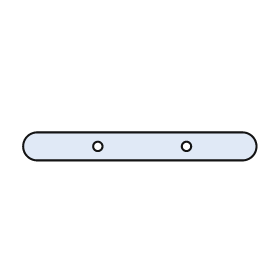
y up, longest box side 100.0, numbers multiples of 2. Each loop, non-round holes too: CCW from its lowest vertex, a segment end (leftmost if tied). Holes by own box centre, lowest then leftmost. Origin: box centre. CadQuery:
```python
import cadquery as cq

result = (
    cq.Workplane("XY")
    .moveTo(-44.0, -6.0)
    .lineTo(44.0, -6.0)
    .threePointArc((50.0, 0.0), (44.0, 6.0))
    .lineTo(-44.0, 6.0)
    .threePointArc((-50.0, 0.0), (-44.0, -6.0))
    .close()
    .moveTo(-18.0, 0.0)
    .circle(2.0)
    .moveTo(20.0, 0.0)
    .circle(2.0)
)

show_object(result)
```